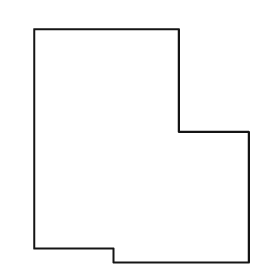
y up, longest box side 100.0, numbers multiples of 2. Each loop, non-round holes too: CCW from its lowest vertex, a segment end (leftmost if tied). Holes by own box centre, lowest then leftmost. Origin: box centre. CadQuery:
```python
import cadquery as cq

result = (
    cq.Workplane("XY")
    .moveTo(-12.0, -50.0)
    .lineTo(46.0, -50.0)
    .lineTo(46.0, 6.0)
    .lineTo(16.0, 6.0)
    .lineTo(16.0, 50.0)
    .lineTo(-46.0, 50.0)
    .lineTo(-46.0, -44.0)
    .lineTo(-12.0, -44.0)
    .close()
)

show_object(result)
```